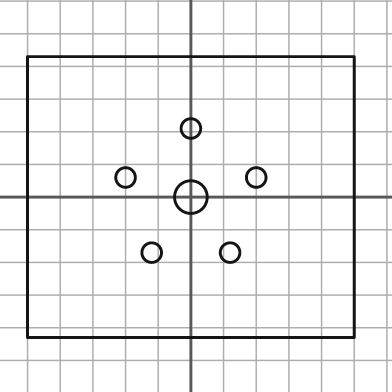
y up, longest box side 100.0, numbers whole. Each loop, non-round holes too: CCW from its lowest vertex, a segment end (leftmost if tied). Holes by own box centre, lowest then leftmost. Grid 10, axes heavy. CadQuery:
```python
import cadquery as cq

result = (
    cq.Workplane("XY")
    .moveTo(-50.0, -43.0)
    .lineTo(50.0, -43.0)
    .lineTo(50.0, 43.0)
    .lineTo(-50.0, 43.0)
    .close()
    .moveTo(-12.0, -17.0)
    .circle(3.0)
    .moveTo(12.0, -17.0)
    .circle(3.0)
    .moveTo(0.0, 0.0)
    .circle(5.0)
    .moveTo(-20.0, 6.0)
    .circle(3.0)
    .moveTo(20.0, 6.0)
    .circle(3.0)
    .moveTo(0.0, 21.0)
    .circle(3.0)
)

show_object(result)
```